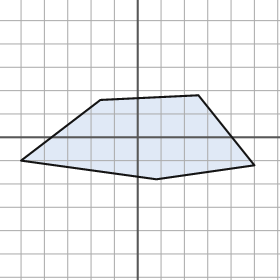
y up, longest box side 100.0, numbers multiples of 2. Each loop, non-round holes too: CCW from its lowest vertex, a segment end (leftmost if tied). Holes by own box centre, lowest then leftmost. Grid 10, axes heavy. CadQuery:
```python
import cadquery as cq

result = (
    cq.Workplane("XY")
    .moveTo(8.0, -18.0)
    .lineTo(50.0, -12.0)
    .lineTo(26.0, 18.0)
    .lineTo(-16.0, 16.0)
    .lineTo(-50.0, -10.0)
    .close()
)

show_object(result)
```